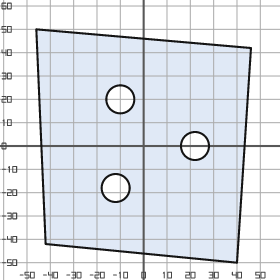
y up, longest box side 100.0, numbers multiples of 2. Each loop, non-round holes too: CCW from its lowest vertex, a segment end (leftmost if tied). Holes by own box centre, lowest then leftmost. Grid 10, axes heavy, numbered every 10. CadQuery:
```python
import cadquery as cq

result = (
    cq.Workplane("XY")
    .moveTo(40.0, -50.0)
    .lineTo(46.0, 42.0)
    .lineTo(-46.0, 50.0)
    .lineTo(-42.0, -42.0)
    .close()
    .moveTo(-12.0, -18.0)
    .circle(6.0)
    .moveTo(22.0, 0.0)
    .circle(6.0)
    .moveTo(-10.0, 20.0)
    .circle(6.0)
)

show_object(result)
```